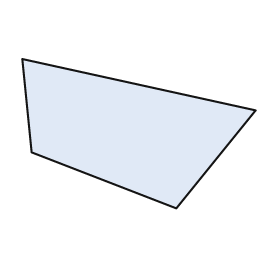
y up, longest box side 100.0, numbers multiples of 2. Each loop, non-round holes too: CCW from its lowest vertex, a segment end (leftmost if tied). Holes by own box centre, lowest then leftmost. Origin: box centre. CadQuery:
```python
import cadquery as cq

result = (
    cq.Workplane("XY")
    .moveTo(16.0, -32.0)
    .lineTo(50.0, 10.0)
    .lineTo(-50.0, 32.0)
    .lineTo(-46.0, -8.0)
    .close()
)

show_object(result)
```